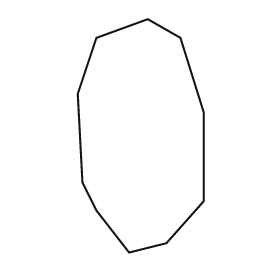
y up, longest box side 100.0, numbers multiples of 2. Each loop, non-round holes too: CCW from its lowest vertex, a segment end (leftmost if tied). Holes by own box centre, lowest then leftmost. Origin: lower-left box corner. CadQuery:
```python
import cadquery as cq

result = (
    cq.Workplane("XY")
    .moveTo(22.0, 0.0)
    .lineTo(38.0, 4.0)
    .lineTo(54.0, 22.0)
    .lineTo(54.0, 60.0)
    .lineTo(44.0, 92.0)
    .lineTo(30.0, 100.0)
    .lineTo(8.0, 92.0)
    .lineTo(0.0, 68.0)
    .lineTo(2.0, 30.0)
    .lineTo(8.0, 18.0)
    .close()
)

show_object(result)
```